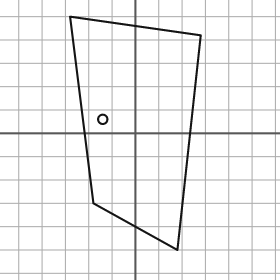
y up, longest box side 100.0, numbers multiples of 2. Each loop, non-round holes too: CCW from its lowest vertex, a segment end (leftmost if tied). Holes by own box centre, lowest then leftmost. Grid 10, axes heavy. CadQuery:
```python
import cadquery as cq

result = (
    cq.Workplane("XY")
    .moveTo(18.0, -50.0)
    .lineTo(28.0, 42.0)
    .lineTo(-28.0, 50.0)
    .lineTo(-18.0, -30.0)
    .close()
    .moveTo(-14.0, 6.0)
    .circle(2.0)
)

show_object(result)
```